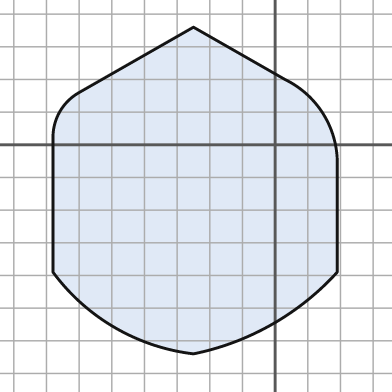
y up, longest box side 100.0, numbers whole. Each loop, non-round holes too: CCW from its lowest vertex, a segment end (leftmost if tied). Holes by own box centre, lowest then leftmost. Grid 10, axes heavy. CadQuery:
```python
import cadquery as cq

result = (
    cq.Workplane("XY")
    .moveTo(-25.0, -64.0)
    .threePointArc((-1.0, -55.0), (19.0, -39.0))
    .lineTo(19.0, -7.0)
    .threePointArc((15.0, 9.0), (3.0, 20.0))
    .lineTo(-25.0, 36.0)
    .lineTo(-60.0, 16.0)
    .threePointArc((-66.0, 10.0), (-68.0, 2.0))
    .lineTo(-68.0, -39.0)
    .threePointArc((-49.0, -56.0), (-25.0, -64.0))
    .close()
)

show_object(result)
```